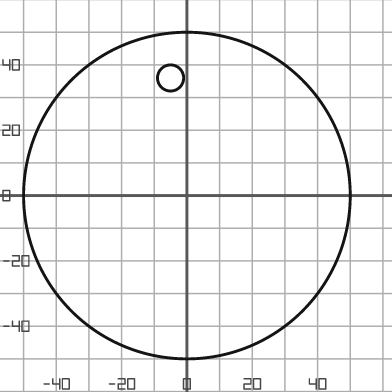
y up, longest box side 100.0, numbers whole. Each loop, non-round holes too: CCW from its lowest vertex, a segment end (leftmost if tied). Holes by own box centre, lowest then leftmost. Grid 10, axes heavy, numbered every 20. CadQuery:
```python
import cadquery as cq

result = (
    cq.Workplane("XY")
    .moveTo(0.0, 0.0)
    .circle(50.0)
    .moveTo(-5.0, 36.0)
    .circle(4.0)
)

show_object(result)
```